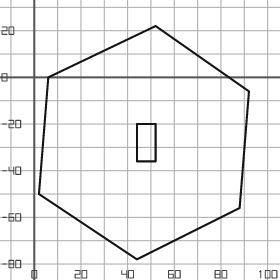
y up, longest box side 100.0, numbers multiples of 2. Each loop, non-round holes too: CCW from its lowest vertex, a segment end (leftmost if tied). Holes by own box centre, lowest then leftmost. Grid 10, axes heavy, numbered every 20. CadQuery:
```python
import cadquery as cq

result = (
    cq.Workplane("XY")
    .moveTo(44.0, -78.0)
    .lineTo(88.0, -56.0)
    .lineTo(92.0, -6.0)
    .lineTo(52.0, 22.0)
    .lineTo(6.0, 0.0)
    .lineTo(2.0, -50.0)
    .close()
    .moveTo(44.0, -36.0)
    .lineTo(52.0, -36.0)
    .lineTo(52.0, -20.0)
    .lineTo(44.0, -20.0)
    .close()
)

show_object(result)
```